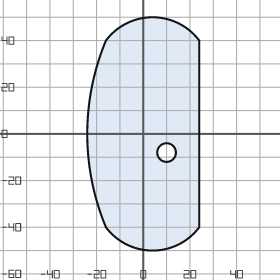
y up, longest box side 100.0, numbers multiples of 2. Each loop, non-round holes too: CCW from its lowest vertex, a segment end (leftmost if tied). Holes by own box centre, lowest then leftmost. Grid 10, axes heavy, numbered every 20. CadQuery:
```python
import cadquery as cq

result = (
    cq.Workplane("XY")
    .moveTo(-16.0, -40.0)
    .threePointArc((4.0, -50.0), (24.0, -40.0))
    .lineTo(24.0, 40.0)
    .threePointArc((4.0, 50.0), (-16.0, 40.0))
    .threePointArc((-24.0, 0.0), (-16.0, -40.0))
    .close()
    .moveTo(10.0, -8.0)
    .circle(4.0)
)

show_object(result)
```